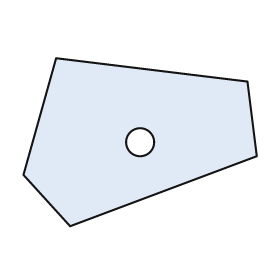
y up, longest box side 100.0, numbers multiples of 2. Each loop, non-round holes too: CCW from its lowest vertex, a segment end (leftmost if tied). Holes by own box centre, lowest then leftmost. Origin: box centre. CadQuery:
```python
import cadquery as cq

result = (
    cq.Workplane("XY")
    .moveTo(-30.0, -36.0)
    .lineTo(50.0, -6.0)
    .lineTo(46.0, 26.0)
    .lineTo(-36.0, 36.0)
    .lineTo(-50.0, -14.0)
    .close()
    .moveTo(0.0, 0.0)
    .circle(6.0)
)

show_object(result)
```